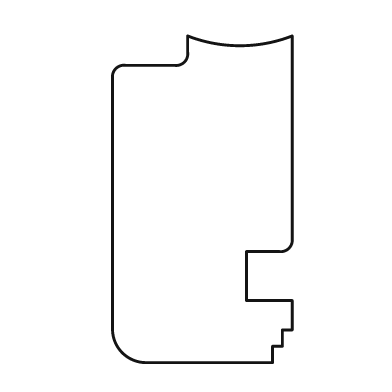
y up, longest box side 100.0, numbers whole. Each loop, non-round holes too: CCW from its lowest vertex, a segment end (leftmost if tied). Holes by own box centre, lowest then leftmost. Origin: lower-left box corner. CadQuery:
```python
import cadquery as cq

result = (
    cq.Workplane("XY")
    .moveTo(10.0, 0.0)
    .lineTo(49.0, 0.0)
    .lineTo(49.0, 5.0)
    .lineTo(52.0, 5.0)
    .lineTo(52.0, 10.0)
    .lineTo(55.0, 10.0)
    .lineTo(55.0, 19.0)
    .lineTo(41.0, 19.0)
    .lineTo(41.0, 34.0)
    .lineTo(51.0, 34.0)
    .threePointArc((54.0, 35.0), (55.0, 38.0))
    .lineTo(55.0, 100.0)
    .threePointArc((39.0, 97.0), (23.0, 100.0))
    .lineTo(23.0, 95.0)
    .threePointArc((22.0, 92.0), (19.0, 91.0))
    .lineTo(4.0, 91.0)
    .threePointArc((1.0, 90.0), (0.0, 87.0))
    .lineTo(0.0, 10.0)
    .threePointArc((3.0, 3.0), (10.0, 0.0))
    .close()
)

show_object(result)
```